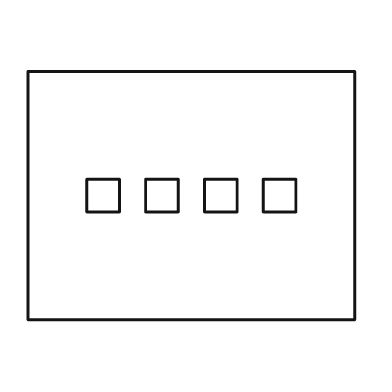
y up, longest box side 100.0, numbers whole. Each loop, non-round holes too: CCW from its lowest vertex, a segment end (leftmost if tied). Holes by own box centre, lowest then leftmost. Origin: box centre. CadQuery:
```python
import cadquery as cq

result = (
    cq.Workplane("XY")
    .moveTo(-50.0, -38.0)
    .lineTo(50.0, -38.0)
    .lineTo(50.0, 38.0)
    .lineTo(-50.0, 38.0)
    .close()
    .moveTo(-32.0, -5.0)
    .lineTo(-22.0, -5.0)
    .lineTo(-22.0, 5.0)
    .lineTo(-32.0, 5.0)
    .close()
    .moveTo(-14.0, -5.0)
    .lineTo(-4.0, -5.0)
    .lineTo(-4.0, 5.0)
    .lineTo(-14.0, 5.0)
    .close()
    .moveTo(4.0, -5.0)
    .lineTo(14.0, -5.0)
    .lineTo(14.0, 5.0)
    .lineTo(4.0, 5.0)
    .close()
    .moveTo(22.0, -5.0)
    .lineTo(32.0, -5.0)
    .lineTo(32.0, 5.0)
    .lineTo(22.0, 5.0)
    .close()
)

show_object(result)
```